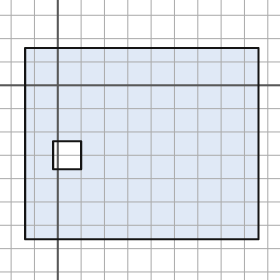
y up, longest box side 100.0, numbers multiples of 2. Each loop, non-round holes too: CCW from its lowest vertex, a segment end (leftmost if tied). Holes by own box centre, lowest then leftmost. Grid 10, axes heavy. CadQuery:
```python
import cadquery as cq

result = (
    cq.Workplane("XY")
    .moveTo(-14.0, -66.0)
    .lineTo(86.0, -66.0)
    .lineTo(86.0, 16.0)
    .lineTo(-14.0, 16.0)
    .close()
    .moveTo(-2.0, -36.0)
    .lineTo(10.0, -36.0)
    .lineTo(10.0, -24.0)
    .lineTo(-2.0, -24.0)
    .close()
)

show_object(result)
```